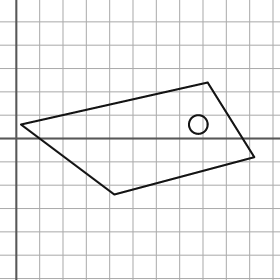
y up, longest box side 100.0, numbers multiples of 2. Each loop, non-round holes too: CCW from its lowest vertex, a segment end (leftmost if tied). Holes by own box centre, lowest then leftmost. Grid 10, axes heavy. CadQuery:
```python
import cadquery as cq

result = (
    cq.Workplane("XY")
    .moveTo(42.0, -24.0)
    .lineTo(102.0, -8.0)
    .lineTo(82.0, 24.0)
    .lineTo(2.0, 6.0)
    .close()
    .moveTo(78.0, 6.0)
    .circle(4.0)
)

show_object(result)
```